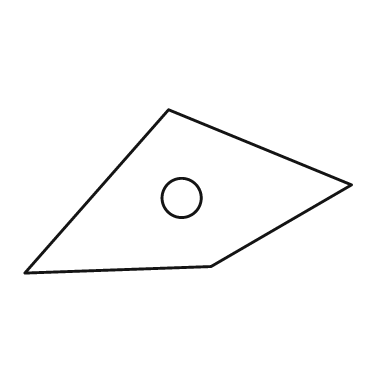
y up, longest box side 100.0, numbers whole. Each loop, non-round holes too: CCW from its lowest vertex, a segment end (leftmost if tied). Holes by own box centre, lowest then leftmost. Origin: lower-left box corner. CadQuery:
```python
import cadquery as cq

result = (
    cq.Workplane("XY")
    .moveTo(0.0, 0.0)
    .lineTo(57.0, 2.0)
    .lineTo(100.0, 27.0)
    .lineTo(44.0, 50.0)
    .close()
    .moveTo(48.0, 23.0)
    .circle(6.0)
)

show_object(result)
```